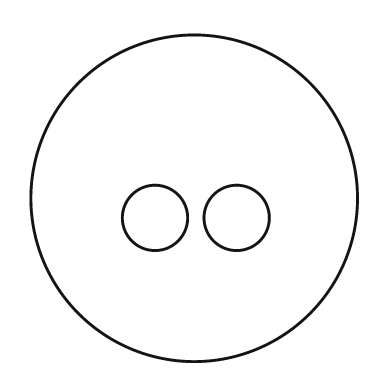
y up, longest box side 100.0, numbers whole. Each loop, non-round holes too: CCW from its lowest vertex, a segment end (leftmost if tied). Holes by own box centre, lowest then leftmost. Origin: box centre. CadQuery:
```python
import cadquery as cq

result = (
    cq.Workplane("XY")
    .moveTo(0.0, 0.0)
    .circle(50.0)
    .moveTo(-12.0, -6.0)
    .circle(10.0)
    .moveTo(13.0, -6.0)
    .circle(10.0)
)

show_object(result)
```